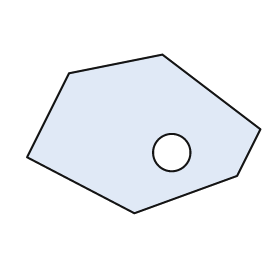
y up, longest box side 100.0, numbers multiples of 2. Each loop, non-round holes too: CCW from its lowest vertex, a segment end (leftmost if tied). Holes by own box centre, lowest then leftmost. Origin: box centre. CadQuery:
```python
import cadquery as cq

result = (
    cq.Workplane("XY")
    .moveTo(-4.0, -34.0)
    .lineTo(40.0, -18.0)
    .lineTo(50.0, 2.0)
    .lineTo(8.0, 34.0)
    .lineTo(-32.0, 26.0)
    .lineTo(-50.0, -10.0)
    .close()
    .moveTo(12.0, -8.0)
    .circle(8.0)
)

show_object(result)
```